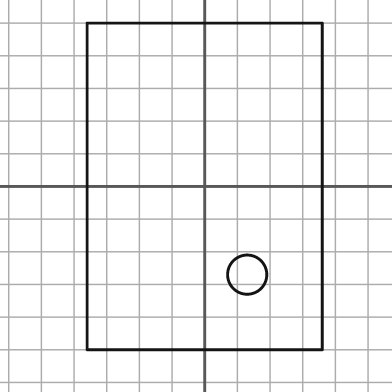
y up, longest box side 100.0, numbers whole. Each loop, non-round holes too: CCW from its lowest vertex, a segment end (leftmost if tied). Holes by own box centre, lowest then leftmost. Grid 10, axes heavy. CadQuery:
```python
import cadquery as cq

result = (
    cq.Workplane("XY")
    .moveTo(-36.0, -50.0)
    .lineTo(36.0, -50.0)
    .lineTo(36.0, 50.0)
    .lineTo(-36.0, 50.0)
    .close()
    .moveTo(13.0, -27.0)
    .circle(6.0)
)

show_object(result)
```